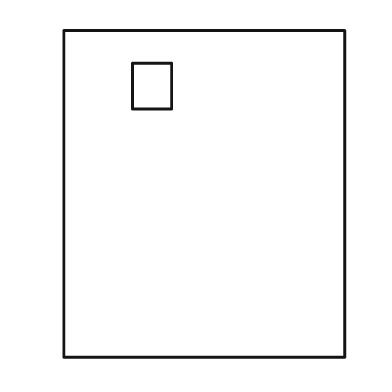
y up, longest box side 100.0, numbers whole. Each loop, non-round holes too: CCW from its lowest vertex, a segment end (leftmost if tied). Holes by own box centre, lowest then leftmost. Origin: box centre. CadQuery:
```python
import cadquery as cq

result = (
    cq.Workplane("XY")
    .moveTo(-43.0, -50.0)
    .lineTo(43.0, -50.0)
    .lineTo(43.0, 50.0)
    .lineTo(-43.0, 50.0)
    .close()
    .moveTo(-22.0, 26.0)
    .lineTo(-10.0, 26.0)
    .lineTo(-10.0, 40.0)
    .lineTo(-22.0, 40.0)
    .close()
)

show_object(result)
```